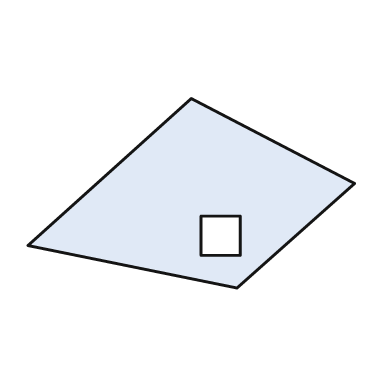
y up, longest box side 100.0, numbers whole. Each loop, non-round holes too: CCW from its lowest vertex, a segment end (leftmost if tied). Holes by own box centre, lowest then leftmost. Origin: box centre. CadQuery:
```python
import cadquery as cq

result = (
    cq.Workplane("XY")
    .moveTo(14.0, -29.0)
    .lineTo(50.0, 3.0)
    .lineTo(0.0, 29.0)
    .lineTo(-50.0, -16.0)
    .close()
    .moveTo(3.0, -19.0)
    .lineTo(15.0, -19.0)
    .lineTo(15.0, -7.0)
    .lineTo(3.0, -7.0)
    .close()
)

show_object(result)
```